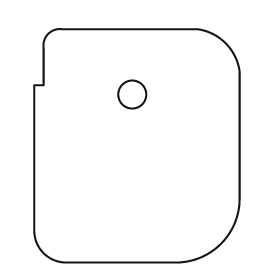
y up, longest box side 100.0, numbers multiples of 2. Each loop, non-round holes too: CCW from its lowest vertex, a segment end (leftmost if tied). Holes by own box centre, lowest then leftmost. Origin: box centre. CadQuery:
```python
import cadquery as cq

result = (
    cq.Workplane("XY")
    .moveTo(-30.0, -50.0)
    .lineTo(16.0, -50.0)
    .threePointArc((36.0, -42.0), (44.0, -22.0))
    .lineTo(44.0, 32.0)
    .threePointArc((38.0, 44.0), (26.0, 50.0))
    .lineTo(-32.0, 50.0)
    .threePointArc((-38.0, 48.0), (-40.0, 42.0))
    .lineTo(-40.0, 26.0)
    .lineTo(-44.0, 26.0)
    .lineTo(-44.0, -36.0)
    .threePointArc((-40.0, -46.0), (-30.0, -50.0))
    .close()
    .moveTo(-2.0, 22.0)
    .circle(6.0)
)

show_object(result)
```